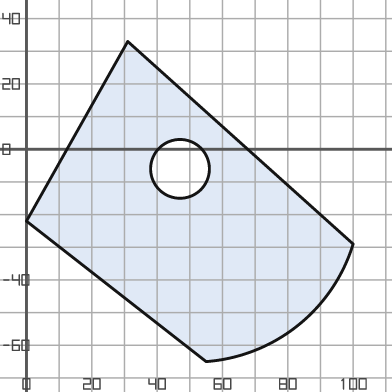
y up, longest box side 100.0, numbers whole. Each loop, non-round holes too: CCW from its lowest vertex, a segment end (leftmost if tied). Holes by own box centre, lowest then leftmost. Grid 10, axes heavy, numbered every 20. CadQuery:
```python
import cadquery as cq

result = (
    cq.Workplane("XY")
    .moveTo(55.0, -65.0)
    .threePointArc((83.0, -54.0), (100.0, -29.0))
    .lineTo(31.0, 33.0)
    .lineTo(0.0, -22.0)
    .close()
    .moveTo(47.0, -6.0)
    .circle(9.0)
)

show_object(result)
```